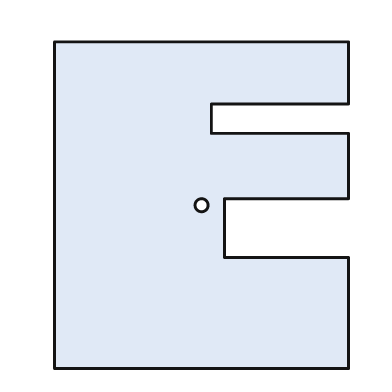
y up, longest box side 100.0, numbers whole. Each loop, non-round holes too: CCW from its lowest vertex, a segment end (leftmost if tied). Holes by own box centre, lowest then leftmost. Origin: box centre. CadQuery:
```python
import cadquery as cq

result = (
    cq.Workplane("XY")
    .moveTo(-45.0, -50.0)
    .lineTo(45.0, -50.0)
    .lineTo(45.0, -16.0)
    .lineTo(7.0, -16.0)
    .lineTo(7.0, 2.0)
    .lineTo(45.0, 2.0)
    .lineTo(45.0, 22.0)
    .lineTo(3.0, 22.0)
    .lineTo(3.0, 31.0)
    .lineTo(45.0, 31.0)
    .lineTo(45.0, 50.0)
    .lineTo(-45.0, 50.0)
    .close()
    .moveTo(0.0, 0.0)
    .circle(2.0)
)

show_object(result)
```